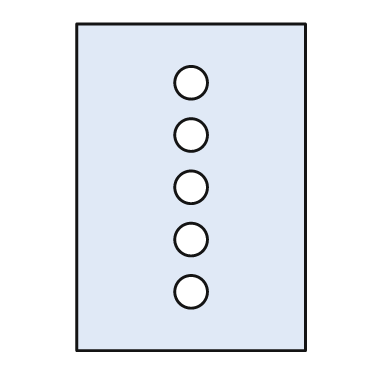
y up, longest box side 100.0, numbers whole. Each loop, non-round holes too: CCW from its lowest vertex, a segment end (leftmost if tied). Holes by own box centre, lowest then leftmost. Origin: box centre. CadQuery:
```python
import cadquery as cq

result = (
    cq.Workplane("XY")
    .moveTo(-35.0, -50.0)
    .lineTo(35.0, -50.0)
    .lineTo(35.0, 50.0)
    .lineTo(-35.0, 50.0)
    .close()
    .moveTo(0.0, -32.0)
    .circle(5.0)
    .moveTo(0.0, -16.0)
    .circle(5.0)
    .moveTo(0.0, 0.0)
    .circle(5.0)
    .moveTo(0.0, 16.0)
    .circle(5.0)
    .moveTo(0.0, 32.0)
    .circle(5.0)
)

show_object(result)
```